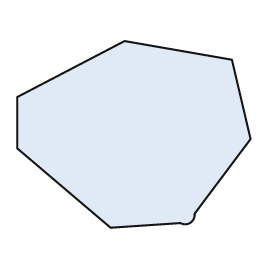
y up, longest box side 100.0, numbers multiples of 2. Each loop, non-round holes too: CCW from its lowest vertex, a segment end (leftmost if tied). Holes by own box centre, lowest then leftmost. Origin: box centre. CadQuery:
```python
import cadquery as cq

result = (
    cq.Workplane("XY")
    .moveTo(-10.0, -40.0)
    .lineTo(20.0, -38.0)
    .threePointArc((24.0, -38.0), (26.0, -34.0))
    .lineTo(50.0, -2.0)
    .lineTo(42.0, 32.0)
    .lineTo(-4.0, 40.0)
    .lineTo(-50.0, 16.0)
    .lineTo(-50.0, -6.0)
    .close()
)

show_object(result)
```